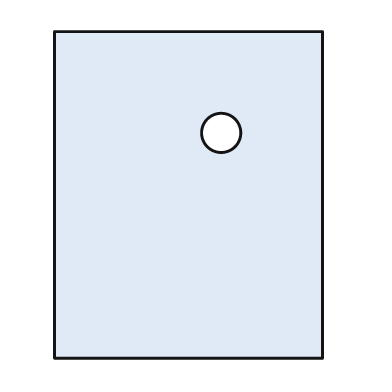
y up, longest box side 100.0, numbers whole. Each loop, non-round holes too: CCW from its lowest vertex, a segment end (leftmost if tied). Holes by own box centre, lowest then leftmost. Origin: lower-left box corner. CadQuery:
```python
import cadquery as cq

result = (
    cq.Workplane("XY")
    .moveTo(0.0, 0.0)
    .lineTo(82.0, 0.0)
    .lineTo(82.0, 100.0)
    .lineTo(0.0, 100.0)
    .close()
    .moveTo(51.0, 69.0)
    .circle(6.0)
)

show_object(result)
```